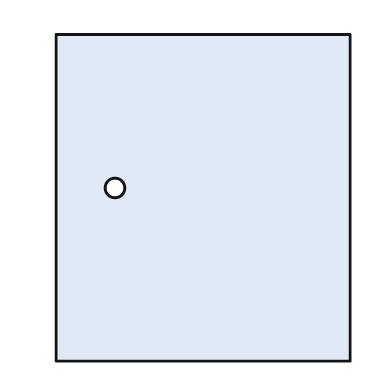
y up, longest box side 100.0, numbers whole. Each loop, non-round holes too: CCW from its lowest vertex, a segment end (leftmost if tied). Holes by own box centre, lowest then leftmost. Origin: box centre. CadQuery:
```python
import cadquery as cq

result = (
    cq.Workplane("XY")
    .moveTo(-45.0, -50.0)
    .lineTo(45.0, -50.0)
    .lineTo(45.0, 50.0)
    .lineTo(-45.0, 50.0)
    .close()
    .moveTo(-27.0, 3.0)
    .circle(3.0)
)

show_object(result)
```